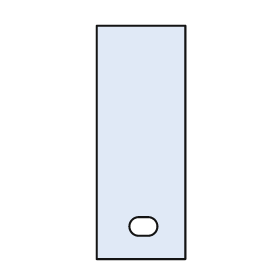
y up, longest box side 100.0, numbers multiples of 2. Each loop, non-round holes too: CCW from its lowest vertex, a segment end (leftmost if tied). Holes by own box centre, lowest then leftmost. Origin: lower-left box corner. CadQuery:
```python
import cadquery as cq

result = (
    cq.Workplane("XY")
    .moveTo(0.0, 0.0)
    .lineTo(38.0, 0.0)
    .lineTo(38.0, 100.0)
    .lineTo(0.0, 100.0)
    .close()
    .moveTo(18.0, 10.0)
    .lineTo(22.0, 10.0)
    .threePointArc((26.0, 14.0), (22.0, 18.0))
    .lineTo(18.0, 18.0)
    .threePointArc((14.0, 14.0), (18.0, 10.0))
    .close()
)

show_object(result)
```